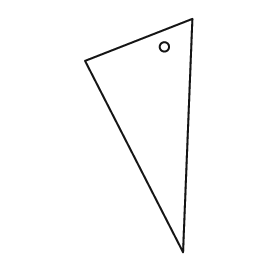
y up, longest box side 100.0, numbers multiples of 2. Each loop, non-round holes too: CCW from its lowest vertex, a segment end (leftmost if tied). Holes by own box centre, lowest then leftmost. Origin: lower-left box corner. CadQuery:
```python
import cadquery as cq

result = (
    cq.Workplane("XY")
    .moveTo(42.0, 0.0)
    .lineTo(46.0, 100.0)
    .lineTo(0.0, 82.0)
    .close()
    .moveTo(34.0, 88.0)
    .circle(2.0)
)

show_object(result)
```